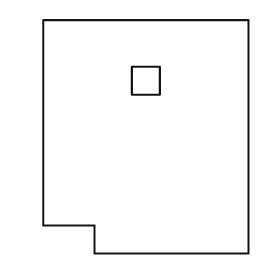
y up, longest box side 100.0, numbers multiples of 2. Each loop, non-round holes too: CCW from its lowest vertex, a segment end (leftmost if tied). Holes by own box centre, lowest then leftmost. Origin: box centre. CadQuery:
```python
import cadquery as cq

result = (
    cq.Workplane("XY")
    .moveTo(-22.0, -50.0)
    .lineTo(44.0, -50.0)
    .lineTo(44.0, 50.0)
    .lineTo(-44.0, 50.0)
    .lineTo(-44.0, -38.0)
    .lineTo(-22.0, -38.0)
    .close()
    .moveTo(-6.0, 18.0)
    .lineTo(6.0, 18.0)
    .lineTo(6.0, 30.0)
    .lineTo(-6.0, 30.0)
    .close()
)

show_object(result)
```